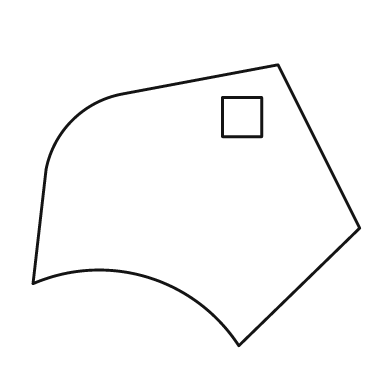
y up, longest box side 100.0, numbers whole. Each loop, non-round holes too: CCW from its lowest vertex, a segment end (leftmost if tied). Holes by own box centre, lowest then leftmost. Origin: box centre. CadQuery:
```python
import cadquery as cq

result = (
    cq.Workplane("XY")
    .moveTo(13.0, -43.0)
    .lineTo(50.0, -7.0)
    .lineTo(25.0, 43.0)
    .lineTo(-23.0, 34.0)
    .threePointArc((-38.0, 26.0), (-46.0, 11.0))
    .lineTo(-50.0, -24.0)
    .threePointArc((-15.0, -22.0), (13.0, -43.0))
    .close()
    .moveTo(8.0, 21.0)
    .lineTo(20.0, 21.0)
    .lineTo(20.0, 33.0)
    .lineTo(8.0, 33.0)
    .close()
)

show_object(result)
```